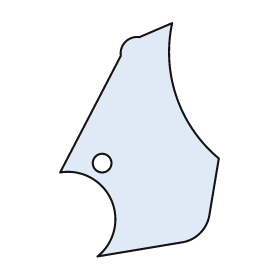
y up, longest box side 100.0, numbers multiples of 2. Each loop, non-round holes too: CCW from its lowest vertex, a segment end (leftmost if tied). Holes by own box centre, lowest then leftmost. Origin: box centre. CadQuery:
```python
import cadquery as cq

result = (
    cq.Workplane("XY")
    .moveTo(-18.0, -50.0)
    .lineTo(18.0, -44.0)
    .threePointArc((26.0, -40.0), (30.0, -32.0))
    .lineTo(34.0, -8.0)
    .threePointArc((16.0, 18.0), (14.0, 50.0))
    .lineTo(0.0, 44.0)
    .threePointArc((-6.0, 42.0), (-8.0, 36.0))
    .lineTo(-34.0, -14.0)
    .threePointArc((-12.0, -26.0), (-18.0, -50.0))
    .close()
    .moveTo(-16.0, -10.0)
    .circle(4.0)
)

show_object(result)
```